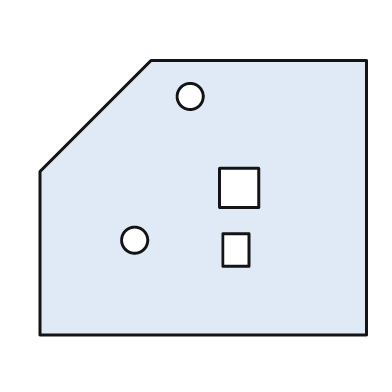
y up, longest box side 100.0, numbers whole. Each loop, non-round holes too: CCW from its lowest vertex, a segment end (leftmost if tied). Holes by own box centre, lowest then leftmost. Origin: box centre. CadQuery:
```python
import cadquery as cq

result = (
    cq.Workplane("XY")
    .moveTo(-50.0, -42.0)
    .lineTo(50.0, -42.0)
    .lineTo(50.0, 42.0)
    .lineTo(-16.0, 42.0)
    .lineTo(-50.0, 8.0)
    .close()
    .moveTo(6.0, -21.0)
    .lineTo(14.0, -21.0)
    .lineTo(14.0, -11.0)
    .lineTo(6.0, -11.0)
    .close()
    .moveTo(-21.0, -13.0)
    .circle(4.0)
    .moveTo(5.0, -3.0)
    .lineTo(17.0, -3.0)
    .lineTo(17.0, 9.0)
    .lineTo(5.0, 9.0)
    .close()
    .moveTo(-4.0, 31.0)
    .circle(4.0)
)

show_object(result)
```